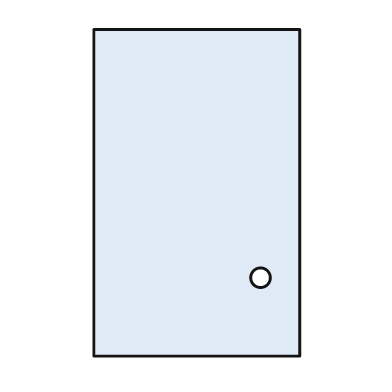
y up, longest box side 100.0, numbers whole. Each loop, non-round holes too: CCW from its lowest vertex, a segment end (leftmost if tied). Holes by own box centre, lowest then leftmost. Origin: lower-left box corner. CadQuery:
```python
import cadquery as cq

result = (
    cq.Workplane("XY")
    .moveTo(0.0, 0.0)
    .lineTo(63.0, 0.0)
    .lineTo(63.0, 100.0)
    .lineTo(0.0, 100.0)
    .close()
    .moveTo(51.0, 24.0)
    .circle(3.0)
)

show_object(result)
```